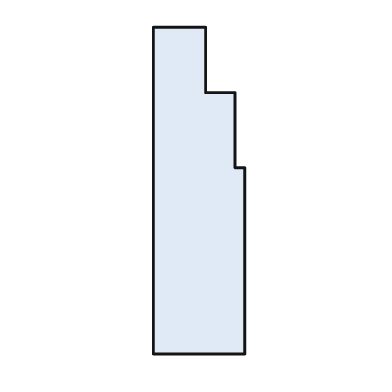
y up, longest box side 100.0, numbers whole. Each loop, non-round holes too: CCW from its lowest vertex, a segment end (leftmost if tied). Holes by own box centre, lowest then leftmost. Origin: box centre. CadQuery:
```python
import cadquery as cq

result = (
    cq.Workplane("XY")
    .moveTo(-14.0, -50.0)
    .lineTo(14.0, -50.0)
    .lineTo(14.0, 7.0)
    .lineTo(11.0, 7.0)
    .lineTo(11.0, 30.0)
    .lineTo(2.0, 30.0)
    .lineTo(2.0, 50.0)
    .lineTo(-14.0, 50.0)
    .close()
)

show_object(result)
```